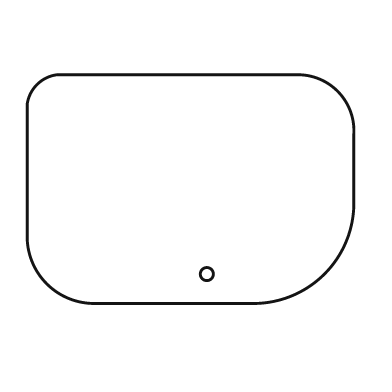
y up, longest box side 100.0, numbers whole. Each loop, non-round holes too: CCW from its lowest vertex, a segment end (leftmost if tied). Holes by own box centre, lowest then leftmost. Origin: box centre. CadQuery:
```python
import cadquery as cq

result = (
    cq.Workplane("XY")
    .moveTo(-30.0, -35.0)
    .lineTo(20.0, -35.0)
    .threePointArc((41.0, -26.0), (50.0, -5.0))
    .lineTo(50.0, 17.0)
    .threePointArc((45.0, 30.0), (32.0, 35.0))
    .lineTo(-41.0, 35.0)
    .threePointArc((-47.0, 32.0), (-50.0, 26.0))
    .lineTo(-50.0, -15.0)
    .threePointArc((-44.0, -29.0), (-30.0, -35.0))
    .close()
    .moveTo(5.0, -26.0)
    .circle(2.0)
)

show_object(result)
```